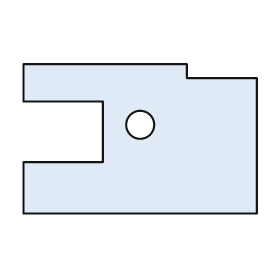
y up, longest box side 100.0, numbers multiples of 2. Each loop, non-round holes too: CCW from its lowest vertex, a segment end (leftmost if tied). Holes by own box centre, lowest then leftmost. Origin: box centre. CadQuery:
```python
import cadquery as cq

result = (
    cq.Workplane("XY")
    .moveTo(-50.0, -32.0)
    .lineTo(50.0, -32.0)
    .lineTo(50.0, 26.0)
    .lineTo(20.0, 26.0)
    .lineTo(20.0, 32.0)
    .lineTo(-50.0, 32.0)
    .lineTo(-50.0, 16.0)
    .lineTo(-16.0, 16.0)
    .lineTo(-16.0, -10.0)
    .lineTo(-50.0, -10.0)
    .close()
    .moveTo(0.0, 6.0)
    .circle(6.0)
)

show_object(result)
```